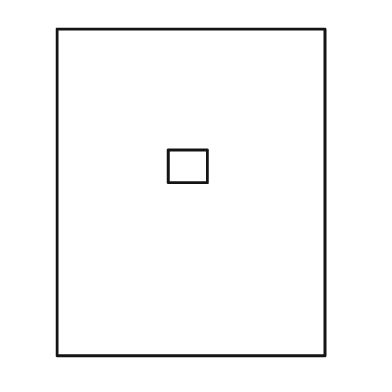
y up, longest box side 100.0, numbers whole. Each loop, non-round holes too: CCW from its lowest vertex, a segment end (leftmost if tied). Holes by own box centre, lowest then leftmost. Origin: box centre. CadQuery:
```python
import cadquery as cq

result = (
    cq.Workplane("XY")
    .moveTo(-41.0, -50.0)
    .lineTo(41.0, -50.0)
    .lineTo(41.0, 50.0)
    .lineTo(-41.0, 50.0)
    .close()
    .moveTo(-7.0, 3.0)
    .lineTo(5.0, 3.0)
    .lineTo(5.0, 13.0)
    .lineTo(-7.0, 13.0)
    .close()
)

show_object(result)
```